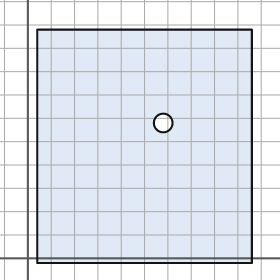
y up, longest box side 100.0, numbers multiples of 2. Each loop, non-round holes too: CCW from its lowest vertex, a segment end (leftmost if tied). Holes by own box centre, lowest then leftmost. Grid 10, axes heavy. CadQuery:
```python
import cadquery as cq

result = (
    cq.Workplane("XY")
    .moveTo(4.0, -2.0)
    .lineTo(96.0, -2.0)
    .lineTo(96.0, 98.0)
    .lineTo(4.0, 98.0)
    .close()
    .moveTo(58.0, 58.0)
    .circle(4.0)
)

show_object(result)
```